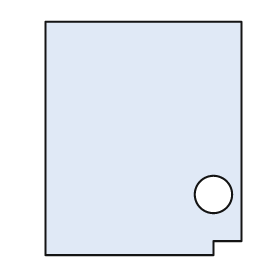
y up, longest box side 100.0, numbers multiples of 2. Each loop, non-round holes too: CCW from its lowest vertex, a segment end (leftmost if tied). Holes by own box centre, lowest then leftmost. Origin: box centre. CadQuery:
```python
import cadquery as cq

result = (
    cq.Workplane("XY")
    .moveTo(-42.0, -50.0)
    .lineTo(30.0, -50.0)
    .lineTo(30.0, -44.0)
    .lineTo(42.0, -44.0)
    .lineTo(42.0, 50.0)
    .lineTo(-42.0, 50.0)
    .close()
    .moveTo(30.0, -24.0)
    .circle(8.0)
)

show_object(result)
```